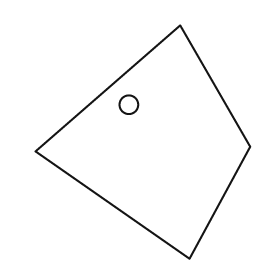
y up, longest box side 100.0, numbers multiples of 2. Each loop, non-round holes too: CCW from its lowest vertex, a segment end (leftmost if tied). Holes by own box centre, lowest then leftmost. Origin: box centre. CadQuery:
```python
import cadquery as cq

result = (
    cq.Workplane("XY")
    .moveTo(20.0, -50.0)
    .lineTo(46.0, -2.0)
    .lineTo(16.0, 50.0)
    .lineTo(-46.0, -4.0)
    .close()
    .moveTo(-6.0, 16.0)
    .circle(4.0)
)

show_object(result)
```